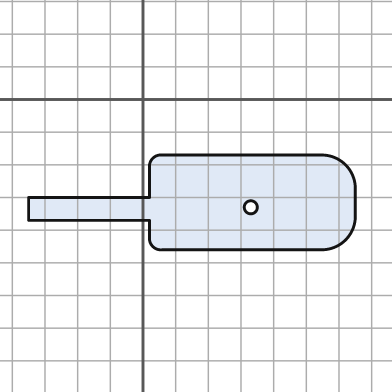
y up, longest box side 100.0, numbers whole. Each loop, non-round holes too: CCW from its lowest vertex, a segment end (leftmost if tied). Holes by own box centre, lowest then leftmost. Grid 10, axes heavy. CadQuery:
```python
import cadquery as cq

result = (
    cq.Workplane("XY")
    .moveTo(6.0, -46.0)
    .lineTo(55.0, -46.0)
    .threePointArc((62.0, -43.0), (65.0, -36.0))
    .lineTo(65.0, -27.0)
    .threePointArc((62.0, -20.0), (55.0, -17.0))
    .lineTo(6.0, -17.0)
    .threePointArc((3.0, -18.0), (2.0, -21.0))
    .lineTo(2.0, -30.0)
    .lineTo(-35.0, -30.0)
    .lineTo(-35.0, -37.0)
    .lineTo(2.0, -37.0)
    .lineTo(2.0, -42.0)
    .threePointArc((3.0, -45.0), (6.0, -46.0))
    .close()
    .moveTo(33.0, -33.0)
    .circle(2.0)
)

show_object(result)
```